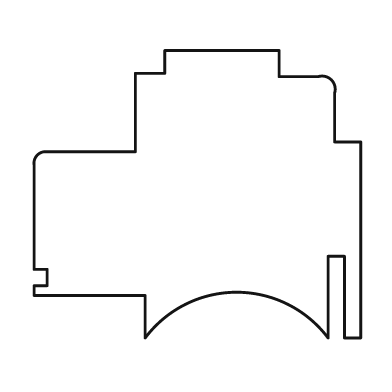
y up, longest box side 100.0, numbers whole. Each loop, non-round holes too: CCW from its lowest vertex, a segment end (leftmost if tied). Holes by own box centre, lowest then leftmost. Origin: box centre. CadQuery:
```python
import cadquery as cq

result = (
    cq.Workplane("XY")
    .moveTo(-16.0, -44.0)
    .threePointArc((12.0, -30.0), (40.0, -44.0))
    .lineTo(40.0, -19.0)
    .lineTo(45.0, -19.0)
    .lineTo(45.0, -44.0)
    .lineTo(50.0, -44.0)
    .lineTo(50.0, 16.0)
    .lineTo(42.0, 16.0)
    .lineTo(42.0, 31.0)
    .threePointArc((41.0, 35.0), (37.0, 36.0))
    .lineTo(25.0, 36.0)
    .lineTo(25.0, 44.0)
    .lineTo(-10.0, 44.0)
    .lineTo(-10.0, 37.0)
    .lineTo(-19.0, 37.0)
    .lineTo(-19.0, 13.0)
    .lineTo(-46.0, 13.0)
    .threePointArc((-49.0, 12.0), (-50.0, 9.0))
    .lineTo(-50.0, -23.0)
    .lineTo(-46.0, -23.0)
    .lineTo(-46.0, -28.0)
    .lineTo(-50.0, -28.0)
    .lineTo(-50.0, -31.0)
    .lineTo(-16.0, -31.0)
    .close()
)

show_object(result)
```